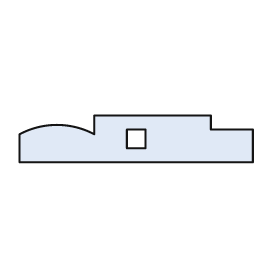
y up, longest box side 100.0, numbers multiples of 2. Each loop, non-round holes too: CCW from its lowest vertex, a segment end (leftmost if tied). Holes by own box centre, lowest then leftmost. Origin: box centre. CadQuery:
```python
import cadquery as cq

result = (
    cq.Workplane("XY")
    .moveTo(-50.0, -10.0)
    .lineTo(50.0, -10.0)
    .lineTo(50.0, 4.0)
    .lineTo(32.0, 4.0)
    .lineTo(32.0, 10.0)
    .lineTo(-18.0, 10.0)
    .lineTo(-18.0, 2.0)
    .threePointArc((-34.0, 6.0), (-50.0, 2.0))
    .close()
    .moveTo(-4.0, -4.0)
    .lineTo(4.0, -4.0)
    .lineTo(4.0, 4.0)
    .lineTo(-4.0, 4.0)
    .close()
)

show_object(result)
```